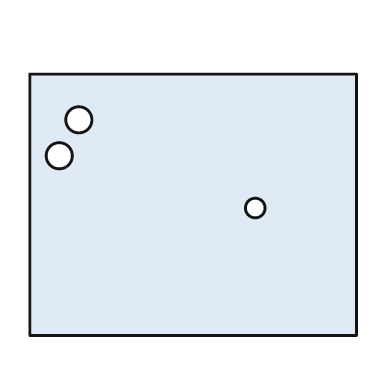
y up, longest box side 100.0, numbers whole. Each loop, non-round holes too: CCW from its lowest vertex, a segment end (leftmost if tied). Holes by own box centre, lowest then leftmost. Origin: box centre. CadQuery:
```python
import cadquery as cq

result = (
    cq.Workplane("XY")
    .moveTo(-50.0, -40.0)
    .lineTo(50.0, -40.0)
    .lineTo(50.0, 40.0)
    .lineTo(-50.0, 40.0)
    .close()
    .moveTo(19.0, -1.0)
    .circle(3.0)
    .moveTo(-41.0, 15.0)
    .circle(4.0)
    .moveTo(-35.0, 26.0)
    .circle(4.0)
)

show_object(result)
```